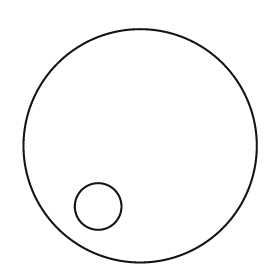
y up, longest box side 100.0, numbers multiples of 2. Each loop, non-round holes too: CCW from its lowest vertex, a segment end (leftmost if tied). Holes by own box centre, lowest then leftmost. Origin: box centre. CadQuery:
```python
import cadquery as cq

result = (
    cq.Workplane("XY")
    .moveTo(0.0, 0.0)
    .circle(50.0)
    .moveTo(-18.0, -26.0)
    .circle(10.0)
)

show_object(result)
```